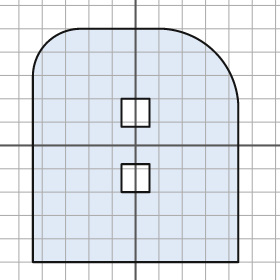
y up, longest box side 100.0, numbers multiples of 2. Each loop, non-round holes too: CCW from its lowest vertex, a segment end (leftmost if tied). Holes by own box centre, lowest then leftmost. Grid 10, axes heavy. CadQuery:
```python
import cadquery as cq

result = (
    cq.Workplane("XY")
    .moveTo(-44.0, -50.0)
    .lineTo(44.0, -50.0)
    .lineTo(44.0, 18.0)
    .threePointArc((34.0, 40.0), (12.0, 50.0))
    .lineTo(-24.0, 50.0)
    .threePointArc((-38.0, 44.0), (-44.0, 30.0))
    .close()
    .moveTo(-6.0, -20.0)
    .lineTo(6.0, -20.0)
    .lineTo(6.0, -8.0)
    .lineTo(-6.0, -8.0)
    .close()
    .moveTo(-6.0, 8.0)
    .lineTo(6.0, 8.0)
    .lineTo(6.0, 20.0)
    .lineTo(-6.0, 20.0)
    .close()
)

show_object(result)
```